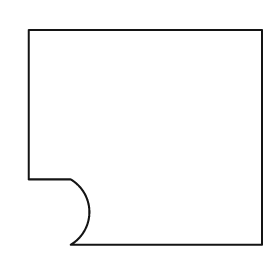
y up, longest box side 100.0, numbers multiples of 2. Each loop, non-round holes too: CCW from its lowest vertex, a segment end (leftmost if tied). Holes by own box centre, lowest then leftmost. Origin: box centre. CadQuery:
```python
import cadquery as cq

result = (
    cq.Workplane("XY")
    .moveTo(-32.0, -46.0)
    .lineTo(50.0, -46.0)
    .lineTo(50.0, 46.0)
    .lineTo(-50.0, 46.0)
    .lineTo(-50.0, -18.0)
    .lineTo(-32.0, -18.0)
    .threePointArc((-24.0, -32.0), (-32.0, -46.0))
    .close()
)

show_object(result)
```